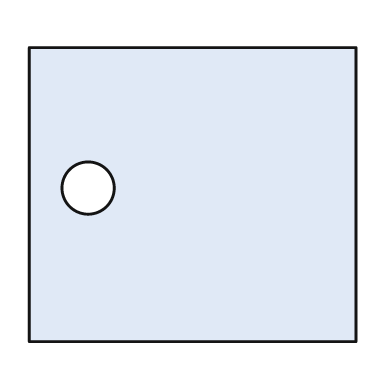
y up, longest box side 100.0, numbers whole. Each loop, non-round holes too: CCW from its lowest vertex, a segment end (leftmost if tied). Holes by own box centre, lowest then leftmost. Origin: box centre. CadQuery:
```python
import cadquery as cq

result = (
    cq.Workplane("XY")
    .moveTo(-50.0, -45.0)
    .lineTo(50.0, -45.0)
    .lineTo(50.0, 45.0)
    .lineTo(-50.0, 45.0)
    .close()
    .moveTo(-32.0, 2.0)
    .circle(8.0)
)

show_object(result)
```